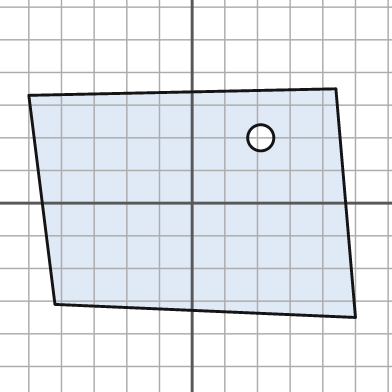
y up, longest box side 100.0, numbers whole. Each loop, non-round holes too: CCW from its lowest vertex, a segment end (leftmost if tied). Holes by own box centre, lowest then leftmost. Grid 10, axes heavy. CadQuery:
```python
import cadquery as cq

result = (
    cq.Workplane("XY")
    .moveTo(50.0, -35.0)
    .lineTo(44.0, 35.0)
    .lineTo(-50.0, 33.0)
    .lineTo(-42.0, -31.0)
    .close()
    .moveTo(21.0, 20.0)
    .circle(4.0)
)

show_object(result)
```